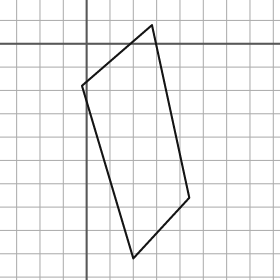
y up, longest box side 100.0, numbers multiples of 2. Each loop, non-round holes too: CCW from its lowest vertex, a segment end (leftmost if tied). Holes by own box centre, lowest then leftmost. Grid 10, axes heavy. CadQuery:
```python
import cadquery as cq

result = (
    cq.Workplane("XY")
    .moveTo(20.0, -92.0)
    .lineTo(44.0, -66.0)
    .lineTo(28.0, 8.0)
    .lineTo(-2.0, -18.0)
    .close()
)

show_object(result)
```